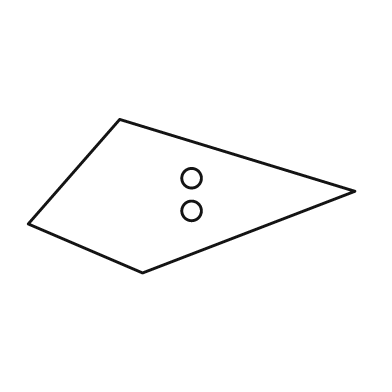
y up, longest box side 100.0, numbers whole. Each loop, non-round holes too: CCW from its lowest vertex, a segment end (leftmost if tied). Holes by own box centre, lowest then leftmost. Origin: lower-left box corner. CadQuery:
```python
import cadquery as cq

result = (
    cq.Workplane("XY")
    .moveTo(35.0, 0.0)
    .lineTo(100.0, 25.0)
    .lineTo(28.0, 47.0)
    .lineTo(0.0, 15.0)
    .close()
    .moveTo(50.0, 19.0)
    .circle(3.0)
    .moveTo(50.0, 29.0)
    .circle(3.0)
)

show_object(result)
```